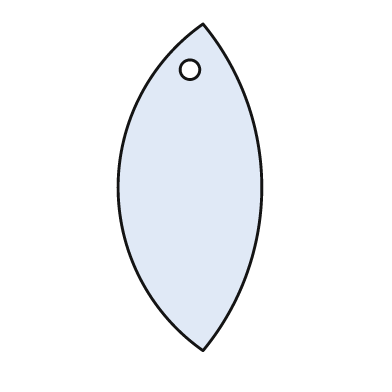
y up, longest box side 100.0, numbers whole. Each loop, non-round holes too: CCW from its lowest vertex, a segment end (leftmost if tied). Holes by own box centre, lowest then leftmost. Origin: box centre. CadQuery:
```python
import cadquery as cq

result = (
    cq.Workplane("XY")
    .moveTo(4.0, -50.0)
    .threePointArc((22.0, 0.0), (4.0, 50.0))
    .threePointArc((-22.0, 0.0), (4.0, -50.0))
    .close()
    .moveTo(0.0, 36.0)
    .circle(3.0)
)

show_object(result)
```